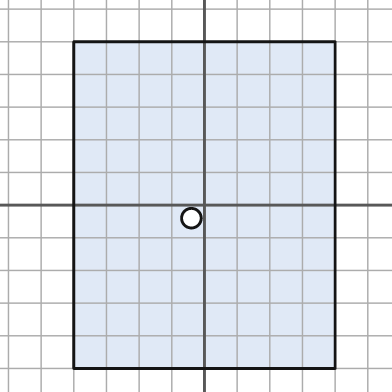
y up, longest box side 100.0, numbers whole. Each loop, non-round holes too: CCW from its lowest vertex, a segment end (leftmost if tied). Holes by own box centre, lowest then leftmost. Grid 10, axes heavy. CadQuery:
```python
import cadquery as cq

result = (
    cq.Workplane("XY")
    .moveTo(-40.0, -50.0)
    .lineTo(40.0, -50.0)
    .lineTo(40.0, 50.0)
    .lineTo(-40.0, 50.0)
    .close()
    .moveTo(-4.0, -4.0)
    .circle(3.0)
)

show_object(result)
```